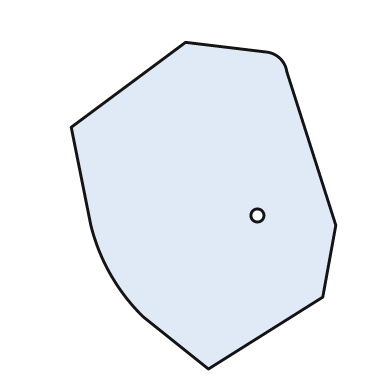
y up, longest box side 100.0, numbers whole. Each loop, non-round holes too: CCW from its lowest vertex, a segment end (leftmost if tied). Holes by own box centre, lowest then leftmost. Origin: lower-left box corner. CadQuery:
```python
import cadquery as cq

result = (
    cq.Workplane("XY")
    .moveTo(42.0, 0.0)
    .lineTo(77.0, 22.0)
    .lineTo(81.0, 44.0)
    .lineTo(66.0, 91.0)
    .threePointArc((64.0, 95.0), (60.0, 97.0))
    .lineTo(35.0, 100.0)
    .lineTo(0.0, 74.0)
    .lineTo(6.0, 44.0)
    .threePointArc((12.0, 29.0), (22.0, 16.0))
    .close()
    .moveTo(57.0, 47.0)
    .circle(2.0)
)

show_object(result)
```